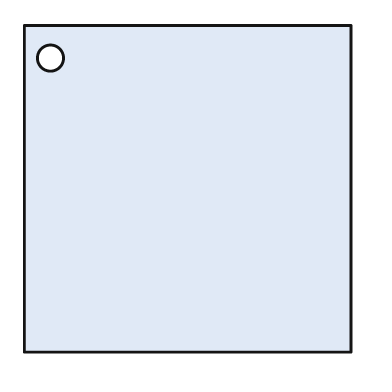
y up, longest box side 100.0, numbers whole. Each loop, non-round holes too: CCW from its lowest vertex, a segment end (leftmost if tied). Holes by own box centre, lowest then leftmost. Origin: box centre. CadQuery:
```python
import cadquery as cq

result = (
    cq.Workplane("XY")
    .moveTo(-50.0, -50.0)
    .lineTo(50.0, -50.0)
    .lineTo(50.0, 50.0)
    .lineTo(-50.0, 50.0)
    .close()
    .moveTo(-42.0, 40.0)
    .circle(4.0)
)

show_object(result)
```